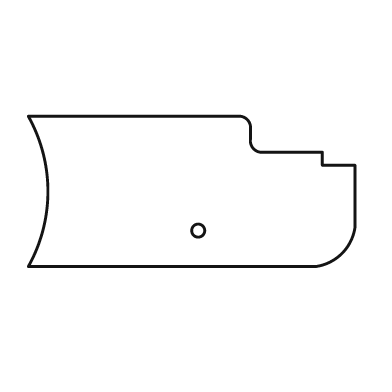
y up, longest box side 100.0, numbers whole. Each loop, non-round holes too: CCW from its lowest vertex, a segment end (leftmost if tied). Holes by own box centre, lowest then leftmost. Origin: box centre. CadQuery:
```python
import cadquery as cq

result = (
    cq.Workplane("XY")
    .moveTo(-50.0, -23.0)
    .lineTo(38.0, -23.0)
    .threePointArc((46.0, -19.0), (50.0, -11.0))
    .lineTo(50.0, 8.0)
    .lineTo(40.0, 8.0)
    .lineTo(40.0, 12.0)
    .lineTo(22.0, 12.0)
    .threePointArc((19.0, 13.0), (18.0, 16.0))
    .lineTo(18.0, 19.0)
    .threePointArc((17.0, 22.0), (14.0, 23.0))
    .lineTo(-50.0, 23.0)
    .threePointArc((-44.0, 0.0), (-50.0, -23.0))
    .close()
    .moveTo(2.0, -12.0)
    .circle(2.0)
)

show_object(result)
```